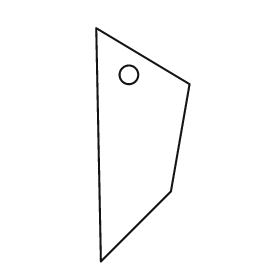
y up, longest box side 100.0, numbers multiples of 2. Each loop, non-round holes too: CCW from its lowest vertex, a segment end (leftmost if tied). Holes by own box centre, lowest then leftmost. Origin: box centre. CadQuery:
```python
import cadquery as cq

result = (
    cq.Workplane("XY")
    .moveTo(-18.0, -50.0)
    .lineTo(12.0, -20.0)
    .lineTo(20.0, 26.0)
    .lineTo(-20.0, 50.0)
    .close()
    .moveTo(-6.0, 30.0)
    .circle(4.0)
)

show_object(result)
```